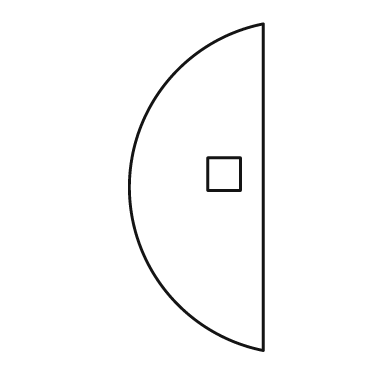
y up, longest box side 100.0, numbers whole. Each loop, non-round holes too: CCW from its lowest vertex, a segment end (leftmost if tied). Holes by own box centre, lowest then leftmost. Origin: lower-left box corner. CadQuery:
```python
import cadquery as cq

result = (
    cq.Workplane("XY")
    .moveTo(41.0, 0.0)
    .lineTo(41.0, 100.0)
    .threePointArc((0.0, 50.0), (41.0, 0.0))
    .close()
    .moveTo(24.0, 49.0)
    .lineTo(34.0, 49.0)
    .lineTo(34.0, 59.0)
    .lineTo(24.0, 59.0)
    .close()
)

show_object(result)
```